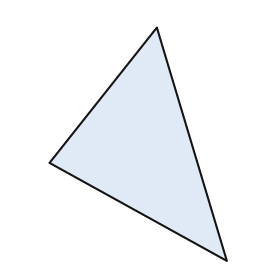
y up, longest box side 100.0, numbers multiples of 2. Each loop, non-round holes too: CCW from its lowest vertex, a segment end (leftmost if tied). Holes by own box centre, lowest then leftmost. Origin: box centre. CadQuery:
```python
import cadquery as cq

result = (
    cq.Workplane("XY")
    .moveTo(38.0, -50.0)
    .lineTo(8.0, 50.0)
    .lineTo(-38.0, -8.0)
    .close()
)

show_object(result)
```